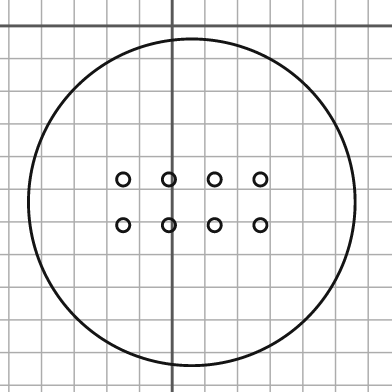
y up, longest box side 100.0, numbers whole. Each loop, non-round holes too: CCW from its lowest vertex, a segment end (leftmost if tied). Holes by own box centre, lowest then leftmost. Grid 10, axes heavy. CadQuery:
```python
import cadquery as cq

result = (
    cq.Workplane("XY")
    .moveTo(6.0, -54.0)
    .circle(50.0)
    .moveTo(-15.0, -61.0)
    .circle(2.0)
    .moveTo(-1.0, -61.0)
    .circle(2.0)
    .moveTo(13.0, -61.0)
    .circle(2.0)
    .moveTo(27.0, -61.0)
    .circle(2.0)
    .moveTo(-15.0, -47.0)
    .circle(2.0)
    .moveTo(-1.0, -47.0)
    .circle(2.0)
    .moveTo(13.0, -47.0)
    .circle(2.0)
    .moveTo(27.0, -47.0)
    .circle(2.0)
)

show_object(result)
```